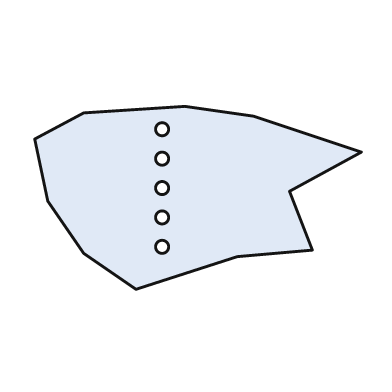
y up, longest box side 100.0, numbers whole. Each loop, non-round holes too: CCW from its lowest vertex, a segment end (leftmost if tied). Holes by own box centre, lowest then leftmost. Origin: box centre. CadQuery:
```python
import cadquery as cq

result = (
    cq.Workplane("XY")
    .moveTo(-19.0, -28.0)
    .lineTo(12.0, -18.0)
    .lineTo(35.0, -16.0)
    .lineTo(28.0, 2.0)
    .lineTo(50.0, 14.0)
    .lineTo(17.0, 25.0)
    .lineTo(-4.0, 28.0)
    .lineTo(-35.0, 26.0)
    .lineTo(-50.0, 18.0)
    .lineTo(-46.0, -1.0)
    .lineTo(-35.0, -17.0)
    .close()
    .moveTo(-11.0, -15.0)
    .circle(2.0)
    .moveTo(-11.0, -6.0)
    .circle(2.0)
    .moveTo(-11.0, 3.0)
    .circle(2.0)
    .moveTo(-11.0, 12.0)
    .circle(2.0)
    .moveTo(-11.0, 21.0)
    .circle(2.0)
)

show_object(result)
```